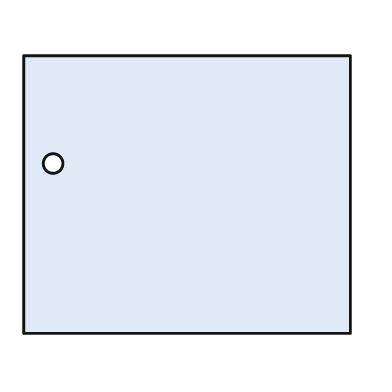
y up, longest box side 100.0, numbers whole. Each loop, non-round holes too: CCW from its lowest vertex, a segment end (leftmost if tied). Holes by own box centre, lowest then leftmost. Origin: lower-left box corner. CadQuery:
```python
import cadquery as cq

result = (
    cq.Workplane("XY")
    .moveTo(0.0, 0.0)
    .lineTo(100.0, 0.0)
    .lineTo(100.0, 85.0)
    .lineTo(0.0, 85.0)
    .close()
    .moveTo(9.0, 52.0)
    .circle(3.0)
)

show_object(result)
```